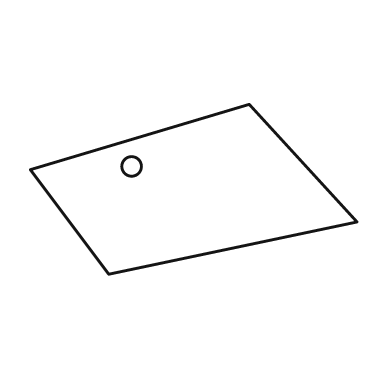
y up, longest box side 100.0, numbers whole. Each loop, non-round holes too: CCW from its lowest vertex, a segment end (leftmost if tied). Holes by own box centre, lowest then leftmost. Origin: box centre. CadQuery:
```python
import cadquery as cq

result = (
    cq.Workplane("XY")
    .moveTo(-26.0, -26.0)
    .lineTo(50.0, -10.0)
    .lineTo(17.0, 26.0)
    .lineTo(-50.0, 6.0)
    .close()
    .moveTo(-19.0, 7.0)
    .circle(3.0)
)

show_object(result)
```